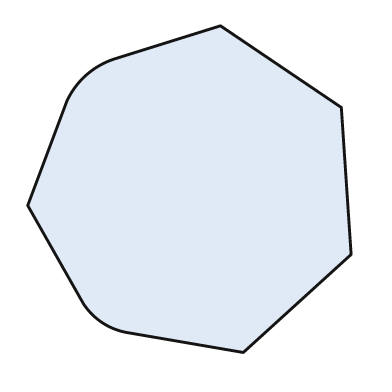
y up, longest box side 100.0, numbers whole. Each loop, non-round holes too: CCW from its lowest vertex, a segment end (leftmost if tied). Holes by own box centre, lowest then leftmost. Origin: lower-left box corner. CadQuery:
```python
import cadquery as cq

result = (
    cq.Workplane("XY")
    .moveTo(66.0, 0.0)
    .lineTo(99.0, 30.0)
    .lineTo(96.0, 75.0)
    .lineTo(59.0, 100.0)
    .lineTo(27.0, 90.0)
    .threePointArc((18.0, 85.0), (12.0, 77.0))
    .lineTo(0.0, 45.0)
    .lineTo(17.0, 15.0)
    .threePointArc((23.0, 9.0), (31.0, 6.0))
    .close()
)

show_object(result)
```